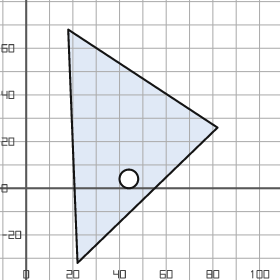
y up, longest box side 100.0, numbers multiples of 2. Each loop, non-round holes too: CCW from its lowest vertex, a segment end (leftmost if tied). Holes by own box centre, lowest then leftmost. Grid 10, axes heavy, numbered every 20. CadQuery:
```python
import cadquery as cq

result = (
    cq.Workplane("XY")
    .moveTo(22.0, -32.0)
    .lineTo(82.0, 26.0)
    .lineTo(18.0, 68.0)
    .close()
    .moveTo(44.0, 4.0)
    .circle(4.0)
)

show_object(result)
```